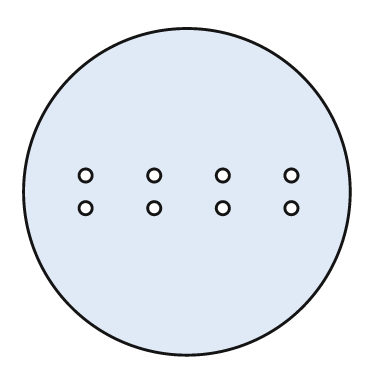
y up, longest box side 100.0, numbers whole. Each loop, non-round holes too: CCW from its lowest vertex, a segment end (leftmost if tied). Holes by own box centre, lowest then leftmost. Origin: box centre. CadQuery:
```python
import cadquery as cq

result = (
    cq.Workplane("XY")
    .moveTo(0.0, 0.0)
    .circle(50.0)
    .moveTo(-31.0, -5.0)
    .circle(2.0)
    .moveTo(-10.0, -5.0)
    .circle(2.0)
    .moveTo(11.0, -5.0)
    .circle(2.0)
    .moveTo(32.0, -5.0)
    .circle(2.0)
    .moveTo(-31.0, 5.0)
    .circle(2.0)
    .moveTo(-10.0, 5.0)
    .circle(2.0)
    .moveTo(11.0, 5.0)
    .circle(2.0)
    .moveTo(32.0, 5.0)
    .circle(2.0)
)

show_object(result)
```